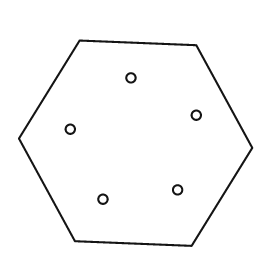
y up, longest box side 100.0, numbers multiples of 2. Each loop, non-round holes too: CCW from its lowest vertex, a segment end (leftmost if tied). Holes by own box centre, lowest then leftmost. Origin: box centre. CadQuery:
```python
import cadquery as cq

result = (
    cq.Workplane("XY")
    .moveTo(24.0, -44.0)
    .lineTo(50.0, -2.0)
    .lineTo(26.0, 42.0)
    .lineTo(-24.0, 44.0)
    .lineTo(-50.0, 2.0)
    .lineTo(-26.0, -42.0)
    .close()
    .moveTo(-14.0, -24.0)
    .circle(2.0)
    .moveTo(18.0, -20.0)
    .circle(2.0)
    .moveTo(-28.0, 6.0)
    .circle(2.0)
    .moveTo(26.0, 12.0)
    .circle(2.0)
    .moveTo(-2.0, 28.0)
    .circle(2.0)
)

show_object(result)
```